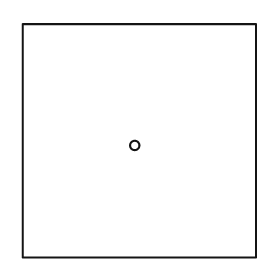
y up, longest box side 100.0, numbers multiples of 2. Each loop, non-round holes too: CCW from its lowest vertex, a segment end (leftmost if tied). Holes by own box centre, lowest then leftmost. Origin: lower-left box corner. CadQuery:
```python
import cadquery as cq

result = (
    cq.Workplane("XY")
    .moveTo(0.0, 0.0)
    .lineTo(100.0, 0.0)
    .lineTo(100.0, 100.0)
    .lineTo(0.0, 100.0)
    .close()
    .moveTo(48.0, 48.0)
    .circle(2.0)
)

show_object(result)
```